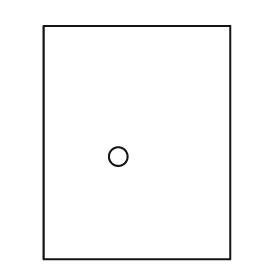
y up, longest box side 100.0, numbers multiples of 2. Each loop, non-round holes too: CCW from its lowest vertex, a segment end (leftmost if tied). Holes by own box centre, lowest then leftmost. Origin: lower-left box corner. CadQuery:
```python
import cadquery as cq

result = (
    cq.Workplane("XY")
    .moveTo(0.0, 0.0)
    .lineTo(80.0, 0.0)
    .lineTo(80.0, 100.0)
    .lineTo(0.0, 100.0)
    .close()
    .moveTo(32.0, 44.0)
    .circle(4.0)
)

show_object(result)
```